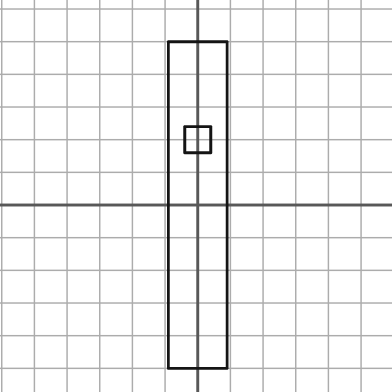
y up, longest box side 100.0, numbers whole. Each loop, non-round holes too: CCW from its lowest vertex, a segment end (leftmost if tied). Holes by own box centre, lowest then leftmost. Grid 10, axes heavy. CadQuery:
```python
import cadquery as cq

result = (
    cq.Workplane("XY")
    .moveTo(-9.0, -50.0)
    .lineTo(9.0, -50.0)
    .lineTo(9.0, 50.0)
    .lineTo(-9.0, 50.0)
    .close()
    .moveTo(-4.0, 16.0)
    .lineTo(4.0, 16.0)
    .lineTo(4.0, 24.0)
    .lineTo(-4.0, 24.0)
    .close()
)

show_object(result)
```